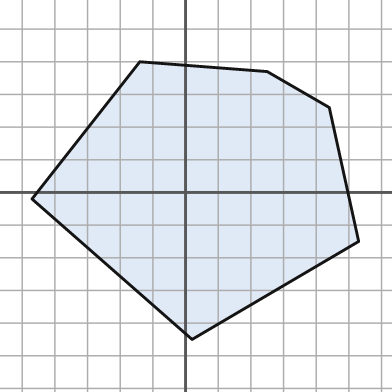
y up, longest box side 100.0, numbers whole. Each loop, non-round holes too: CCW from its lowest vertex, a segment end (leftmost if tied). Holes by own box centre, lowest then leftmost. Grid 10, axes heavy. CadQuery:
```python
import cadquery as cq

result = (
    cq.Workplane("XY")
    .moveTo(2.0, -45.0)
    .lineTo(53.0, -15.0)
    .lineTo(44.0, 26.0)
    .lineTo(25.0, 37.0)
    .lineTo(-14.0, 40.0)
    .lineTo(-47.0, -2.0)
    .close()
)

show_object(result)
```